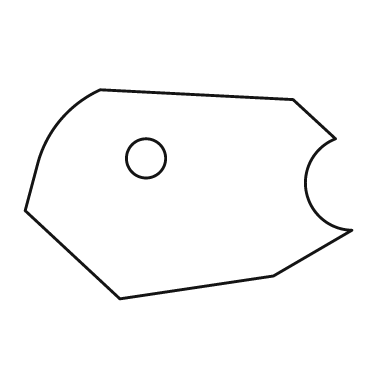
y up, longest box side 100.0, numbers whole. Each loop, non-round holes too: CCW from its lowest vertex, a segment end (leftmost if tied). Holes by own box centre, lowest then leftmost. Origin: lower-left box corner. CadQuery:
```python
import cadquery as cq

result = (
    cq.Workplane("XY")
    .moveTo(29.0, 0.0)
    .lineTo(76.0, 7.0)
    .lineTo(100.0, 21.0)
    .threePointArc((86.0, 33.0), (95.0, 49.0))
    .lineTo(82.0, 61.0)
    .lineTo(23.0, 64.0)
    .threePointArc((11.0, 55.0), (4.0, 42.0))
    .lineTo(0.0, 27.0)
    .close()
    .moveTo(37.0, 43.0)
    .circle(6.0)
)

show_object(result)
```